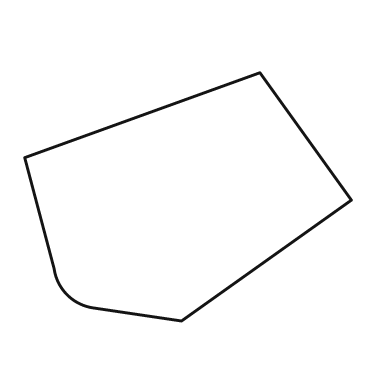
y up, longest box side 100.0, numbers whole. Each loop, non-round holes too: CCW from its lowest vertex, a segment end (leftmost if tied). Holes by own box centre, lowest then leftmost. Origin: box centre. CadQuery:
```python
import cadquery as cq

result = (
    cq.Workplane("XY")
    .moveTo(-2.0, -38.0)
    .lineTo(50.0, -1.0)
    .lineTo(22.0, 38.0)
    .lineTo(-50.0, 12.0)
    .lineTo(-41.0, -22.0)
    .threePointArc((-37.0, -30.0), (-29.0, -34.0))
    .close()
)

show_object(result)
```